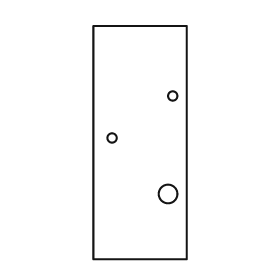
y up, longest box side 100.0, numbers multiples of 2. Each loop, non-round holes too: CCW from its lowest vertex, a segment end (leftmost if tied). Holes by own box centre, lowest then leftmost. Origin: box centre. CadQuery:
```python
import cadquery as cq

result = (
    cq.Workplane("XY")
    .moveTo(-20.0, -50.0)
    .lineTo(20.0, -50.0)
    .lineTo(20.0, 50.0)
    .lineTo(-20.0, 50.0)
    .close()
    .moveTo(12.0, -22.0)
    .circle(4.0)
    .moveTo(-12.0, 2.0)
    .circle(2.0)
    .moveTo(14.0, 20.0)
    .circle(2.0)
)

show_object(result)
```